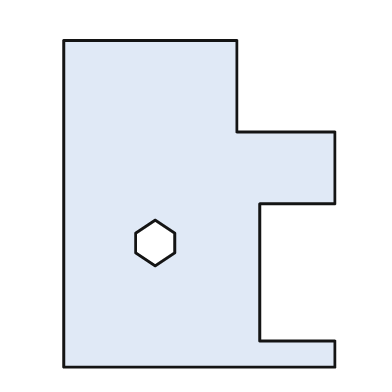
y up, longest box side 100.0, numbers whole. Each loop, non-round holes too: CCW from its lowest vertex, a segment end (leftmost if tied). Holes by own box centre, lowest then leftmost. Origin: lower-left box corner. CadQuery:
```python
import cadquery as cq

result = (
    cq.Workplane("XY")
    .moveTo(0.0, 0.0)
    .lineTo(83.0, 0.0)
    .lineTo(83.0, 8.0)
    .lineTo(60.0, 8.0)
    .lineTo(60.0, 50.0)
    .lineTo(83.0, 50.0)
    .lineTo(83.0, 72.0)
    .lineTo(53.0, 72.0)
    .lineTo(53.0, 100.0)
    .lineTo(0.0, 100.0)
    .close()
    .moveTo(28.0, 31.0)
    .lineTo(34.0, 35.0)
    .lineTo(34.0, 41.0)
    .lineTo(28.0, 45.0)
    .lineTo(22.0, 41.0)
    .lineTo(22.0, 35.0)
    .close()
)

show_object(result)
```